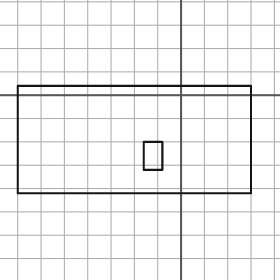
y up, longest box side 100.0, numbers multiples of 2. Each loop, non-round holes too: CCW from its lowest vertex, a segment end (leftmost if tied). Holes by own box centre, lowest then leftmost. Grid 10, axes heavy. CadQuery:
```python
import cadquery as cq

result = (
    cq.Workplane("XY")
    .moveTo(-70.0, -42.0)
    .lineTo(30.0, -42.0)
    .lineTo(30.0, 4.0)
    .lineTo(-70.0, 4.0)
    .close()
    .moveTo(-16.0, -32.0)
    .lineTo(-8.0, -32.0)
    .lineTo(-8.0, -20.0)
    .lineTo(-16.0, -20.0)
    .close()
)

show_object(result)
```